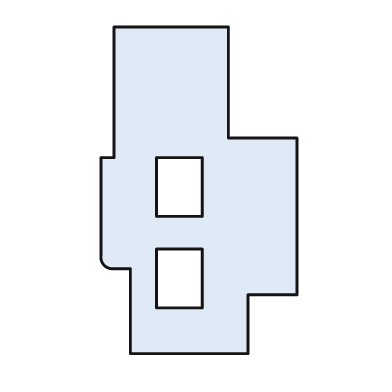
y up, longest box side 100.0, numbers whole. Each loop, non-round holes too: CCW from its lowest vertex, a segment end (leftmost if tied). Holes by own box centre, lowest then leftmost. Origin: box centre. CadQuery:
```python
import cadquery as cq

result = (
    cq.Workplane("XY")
    .moveTo(-21.0, -50.0)
    .lineTo(15.0, -50.0)
    .lineTo(15.0, -32.0)
    .lineTo(30.0, -32.0)
    .lineTo(30.0, 16.0)
    .lineTo(9.0, 16.0)
    .lineTo(9.0, 50.0)
    .lineTo(-26.0, 50.0)
    .lineTo(-26.0, 10.0)
    .lineTo(-30.0, 10.0)
    .lineTo(-30.0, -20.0)
    .threePointArc((-29.0, -23.0), (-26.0, -24.0))
    .lineTo(-21.0, -24.0)
    .close()
    .moveTo(-13.0, -36.0)
    .lineTo(1.0, -36.0)
    .lineTo(1.0, -18.0)
    .lineTo(-13.0, -18.0)
    .close()
    .moveTo(-13.0, -8.0)
    .lineTo(1.0, -8.0)
    .lineTo(1.0, 10.0)
    .lineTo(-13.0, 10.0)
    .close()
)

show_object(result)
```